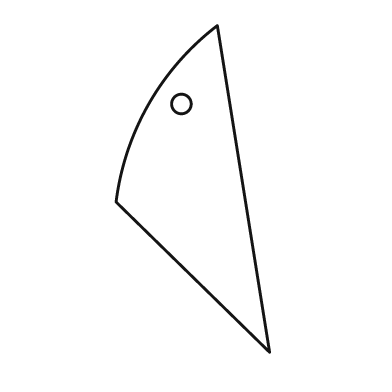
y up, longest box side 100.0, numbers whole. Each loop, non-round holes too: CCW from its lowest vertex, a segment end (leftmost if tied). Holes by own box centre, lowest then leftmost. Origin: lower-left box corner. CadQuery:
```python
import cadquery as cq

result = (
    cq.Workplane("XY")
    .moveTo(47.0, 0.0)
    .lineTo(31.0, 100.0)
    .threePointArc((10.0, 76.0), (0.0, 46.0))
    .close()
    .moveTo(20.0, 76.0)
    .circle(3.0)
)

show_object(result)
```